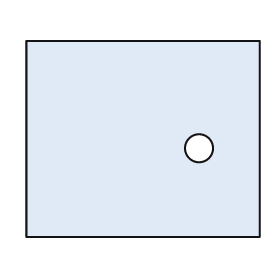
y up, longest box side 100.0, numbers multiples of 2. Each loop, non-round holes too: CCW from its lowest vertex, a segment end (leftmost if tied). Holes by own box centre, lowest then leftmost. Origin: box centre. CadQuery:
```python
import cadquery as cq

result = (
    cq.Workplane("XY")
    .moveTo(-50.0, -42.0)
    .lineTo(50.0, -42.0)
    .lineTo(50.0, 42.0)
    .lineTo(-50.0, 42.0)
    .close()
    .moveTo(24.0, -4.0)
    .circle(6.0)
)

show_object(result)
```